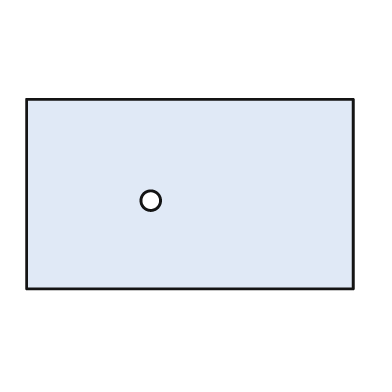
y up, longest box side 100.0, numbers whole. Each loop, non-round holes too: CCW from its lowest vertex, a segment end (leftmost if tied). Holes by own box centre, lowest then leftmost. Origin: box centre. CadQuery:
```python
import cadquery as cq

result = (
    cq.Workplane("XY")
    .moveTo(-50.0, -29.0)
    .lineTo(50.0, -29.0)
    .lineTo(50.0, 29.0)
    .lineTo(-50.0, 29.0)
    .close()
    .moveTo(-12.0, -2.0)
    .circle(3.0)
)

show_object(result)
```